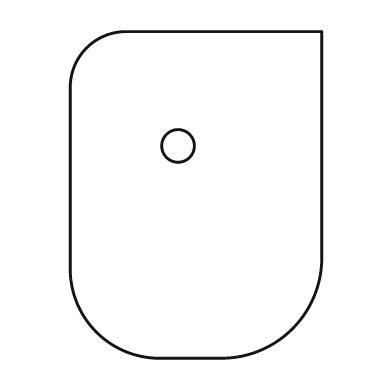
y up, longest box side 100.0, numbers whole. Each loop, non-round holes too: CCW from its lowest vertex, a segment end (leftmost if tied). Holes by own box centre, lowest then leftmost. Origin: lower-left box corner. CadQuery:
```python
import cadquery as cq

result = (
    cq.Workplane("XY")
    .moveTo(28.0, 0.0)
    .lineTo(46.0, 0.0)
    .threePointArc((68.0, 9.0), (77.0, 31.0))
    .lineTo(77.0, 100.0)
    .lineTo(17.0, 100.0)
    .threePointArc((5.0, 95.0), (0.0, 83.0))
    .lineTo(0.0, 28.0)
    .threePointArc((8.0, 8.0), (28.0, 0.0))
    .close()
    .moveTo(33.0, 65.0)
    .circle(5.0)
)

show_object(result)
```